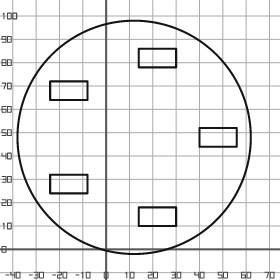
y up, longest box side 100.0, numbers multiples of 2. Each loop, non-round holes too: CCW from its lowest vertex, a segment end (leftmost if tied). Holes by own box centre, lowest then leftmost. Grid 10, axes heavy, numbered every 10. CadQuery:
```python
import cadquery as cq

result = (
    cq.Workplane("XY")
    .moveTo(12.0, 48.0)
    .circle(50.0)
    .moveTo(14.0, 10.0)
    .lineTo(30.0, 10.0)
    .lineTo(30.0, 18.0)
    .lineTo(14.0, 18.0)
    .close()
    .moveTo(-24.0, 24.0)
    .lineTo(-8.0, 24.0)
    .lineTo(-8.0, 32.0)
    .lineTo(-24.0, 32.0)
    .close()
    .moveTo(40.0, 44.0)
    .lineTo(56.0, 44.0)
    .lineTo(56.0, 52.0)
    .lineTo(40.0, 52.0)
    .close()
    .moveTo(-24.0, 64.0)
    .lineTo(-8.0, 64.0)
    .lineTo(-8.0, 72.0)
    .lineTo(-24.0, 72.0)
    .close()
    .moveTo(14.0, 78.0)
    .lineTo(30.0, 78.0)
    .lineTo(30.0, 86.0)
    .lineTo(14.0, 86.0)
    .close()
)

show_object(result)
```